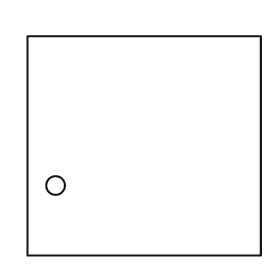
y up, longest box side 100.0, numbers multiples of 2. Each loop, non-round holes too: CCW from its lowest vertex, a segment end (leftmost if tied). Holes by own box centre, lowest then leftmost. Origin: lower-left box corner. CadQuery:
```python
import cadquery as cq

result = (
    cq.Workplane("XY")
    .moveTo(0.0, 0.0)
    .lineTo(100.0, 0.0)
    .lineTo(100.0, 94.0)
    .lineTo(0.0, 94.0)
    .close()
    .moveTo(12.0, 30.0)
    .circle(4.0)
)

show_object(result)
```